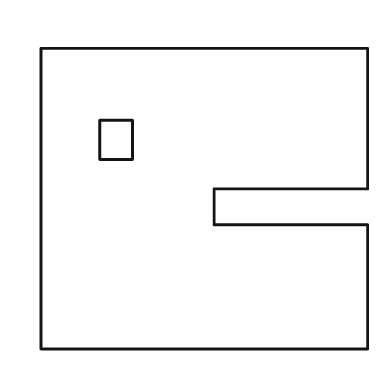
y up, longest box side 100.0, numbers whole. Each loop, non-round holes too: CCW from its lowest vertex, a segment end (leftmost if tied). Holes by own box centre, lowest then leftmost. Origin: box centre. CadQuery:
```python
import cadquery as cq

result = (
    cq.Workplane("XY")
    .moveTo(-50.0, -46.0)
    .lineTo(50.0, -46.0)
    .lineTo(50.0, -8.0)
    .lineTo(3.0, -8.0)
    .lineTo(3.0, 3.0)
    .lineTo(50.0, 3.0)
    .lineTo(50.0, 46.0)
    .lineTo(-50.0, 46.0)
    .close()
    .moveTo(-32.0, 12.0)
    .lineTo(-22.0, 12.0)
    .lineTo(-22.0, 24.0)
    .lineTo(-32.0, 24.0)
    .close()
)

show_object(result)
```